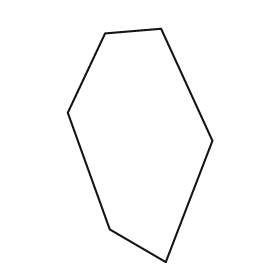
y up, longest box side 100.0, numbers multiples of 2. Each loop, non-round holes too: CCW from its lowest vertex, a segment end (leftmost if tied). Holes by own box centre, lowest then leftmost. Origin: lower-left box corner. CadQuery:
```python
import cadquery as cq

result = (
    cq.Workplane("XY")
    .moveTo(42.0, 0.0)
    .lineTo(62.0, 52.0)
    .lineTo(40.0, 100.0)
    .lineTo(16.0, 98.0)
    .lineTo(0.0, 64.0)
    .lineTo(18.0, 14.0)
    .close()
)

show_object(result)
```